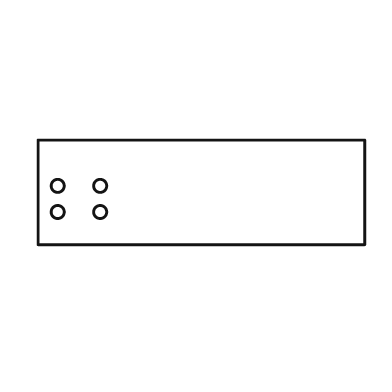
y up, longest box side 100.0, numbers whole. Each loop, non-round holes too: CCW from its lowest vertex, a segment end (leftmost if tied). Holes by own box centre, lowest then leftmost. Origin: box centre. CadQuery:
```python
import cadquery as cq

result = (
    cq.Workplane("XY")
    .moveTo(-50.0, -16.0)
    .lineTo(50.0, -16.0)
    .lineTo(50.0, 16.0)
    .lineTo(-50.0, 16.0)
    .close()
    .moveTo(-44.0, -6.0)
    .circle(2.0)
    .moveTo(-31.0, -6.0)
    .circle(2.0)
    .moveTo(-44.0, 2.0)
    .circle(2.0)
    .moveTo(-31.0, 2.0)
    .circle(2.0)
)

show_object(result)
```